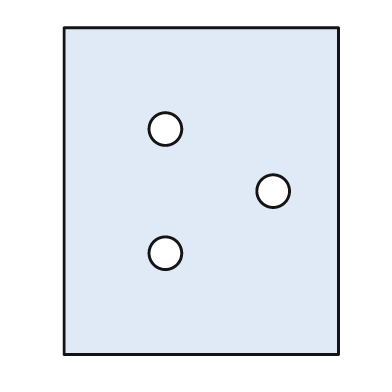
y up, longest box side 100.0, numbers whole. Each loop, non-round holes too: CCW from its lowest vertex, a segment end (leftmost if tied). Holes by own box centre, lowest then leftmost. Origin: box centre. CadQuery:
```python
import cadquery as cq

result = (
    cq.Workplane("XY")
    .moveTo(-42.0, -50.0)
    .lineTo(42.0, -50.0)
    .lineTo(42.0, 50.0)
    .lineTo(-42.0, 50.0)
    .close()
    .moveTo(-11.0, -19.0)
    .circle(5.0)
    .moveTo(22.0, 0.0)
    .circle(5.0)
    .moveTo(-11.0, 19.0)
    .circle(5.0)
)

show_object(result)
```